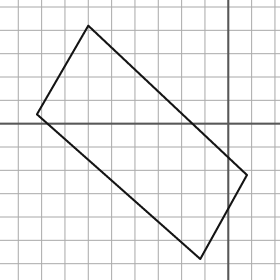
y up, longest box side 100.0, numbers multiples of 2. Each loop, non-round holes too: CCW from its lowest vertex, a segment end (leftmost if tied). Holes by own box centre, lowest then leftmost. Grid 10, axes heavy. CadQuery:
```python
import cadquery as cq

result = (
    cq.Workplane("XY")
    .moveTo(-12.0, -58.0)
    .lineTo(8.0, -22.0)
    .lineTo(-60.0, 42.0)
    .lineTo(-82.0, 4.0)
    .close()
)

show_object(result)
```